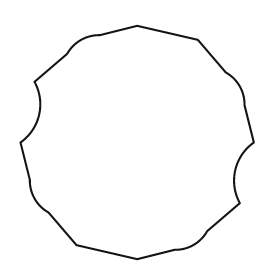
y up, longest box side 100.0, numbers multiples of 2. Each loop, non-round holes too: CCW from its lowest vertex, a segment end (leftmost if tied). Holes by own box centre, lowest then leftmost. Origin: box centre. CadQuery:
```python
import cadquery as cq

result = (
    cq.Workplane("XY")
    .moveTo(0.0, -50.0)
    .lineTo(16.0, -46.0)
    .threePointArc((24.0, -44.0), (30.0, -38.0))
    .lineTo(44.0, -26.0)
    .threePointArc((42.0, -12.0), (50.0, 0.0))
    .lineTo(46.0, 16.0)
    .threePointArc((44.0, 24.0), (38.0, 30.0))
    .lineTo(26.0, 44.0)
    .lineTo(0.0, 50.0)
    .lineTo(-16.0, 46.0)
    .threePointArc((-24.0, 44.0), (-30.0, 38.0))
    .lineTo(-44.0, 26.0)
    .threePointArc((-42.0, 12.0), (-50.0, 0.0))
    .lineTo(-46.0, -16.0)
    .threePointArc((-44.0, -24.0), (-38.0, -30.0))
    .lineTo(-26.0, -44.0)
    .close()
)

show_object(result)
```